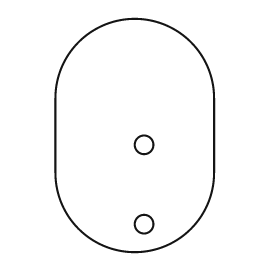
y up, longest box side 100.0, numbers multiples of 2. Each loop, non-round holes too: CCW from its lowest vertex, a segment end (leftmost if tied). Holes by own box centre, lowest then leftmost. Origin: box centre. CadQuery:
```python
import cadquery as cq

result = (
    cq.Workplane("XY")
    .moveTo(-34.0, -16.0)
    .threePointArc((0.0, -50.0), (34.0, -16.0))
    .lineTo(34.0, 16.0)
    .threePointArc((0.0, 50.0), (-34.0, 16.0))
    .close()
    .moveTo(4.0, -38.0)
    .circle(4.0)
    .moveTo(4.0, -4.0)
    .circle(4.0)
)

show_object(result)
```